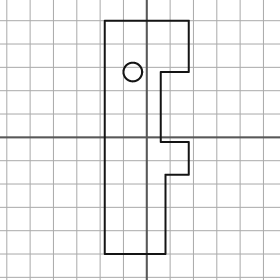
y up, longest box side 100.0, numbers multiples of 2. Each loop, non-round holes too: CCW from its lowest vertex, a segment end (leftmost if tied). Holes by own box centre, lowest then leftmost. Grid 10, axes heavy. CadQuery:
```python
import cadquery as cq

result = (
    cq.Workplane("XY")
    .moveTo(-18.0, -50.0)
    .lineTo(8.0, -50.0)
    .lineTo(8.0, -16.0)
    .lineTo(18.0, -16.0)
    .lineTo(18.0, -2.0)
    .lineTo(6.0, -2.0)
    .lineTo(6.0, 28.0)
    .lineTo(18.0, 28.0)
    .lineTo(18.0, 50.0)
    .lineTo(-18.0, 50.0)
    .close()
    .moveTo(-6.0, 28.0)
    .circle(4.0)
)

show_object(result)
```